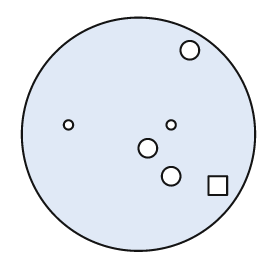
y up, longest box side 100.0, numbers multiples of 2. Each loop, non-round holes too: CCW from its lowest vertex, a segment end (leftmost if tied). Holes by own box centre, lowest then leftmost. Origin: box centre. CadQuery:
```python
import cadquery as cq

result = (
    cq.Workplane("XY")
    .moveTo(0.0, 0.0)
    .circle(50.0)
    .moveTo(30.0, -26.0)
    .lineTo(38.0, -26.0)
    .lineTo(38.0, -18.0)
    .lineTo(30.0, -18.0)
    .close()
    .moveTo(14.0, -18.0)
    .circle(4.0)
    .moveTo(4.0, -6.0)
    .circle(4.0)
    .moveTo(-30.0, 4.0)
    .circle(2.0)
    .moveTo(14.0, 4.0)
    .circle(2.0)
    .moveTo(22.0, 36.0)
    .circle(4.0)
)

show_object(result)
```